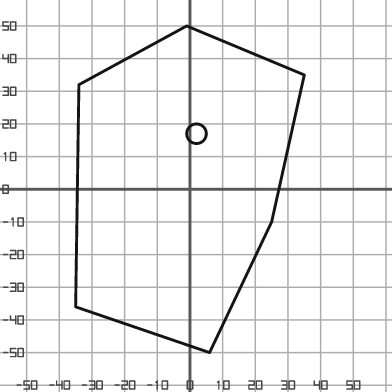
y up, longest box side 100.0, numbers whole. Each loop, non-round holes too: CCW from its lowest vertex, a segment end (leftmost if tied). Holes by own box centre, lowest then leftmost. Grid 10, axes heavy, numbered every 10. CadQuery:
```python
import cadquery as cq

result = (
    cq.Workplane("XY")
    .moveTo(6.0, -50.0)
    .lineTo(25.0, -10.0)
    .lineTo(35.0, 35.0)
    .lineTo(-1.0, 50.0)
    .lineTo(-34.0, 32.0)
    .lineTo(-35.0, -36.0)
    .close()
    .moveTo(2.0, 17.0)
    .circle(3.0)
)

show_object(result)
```